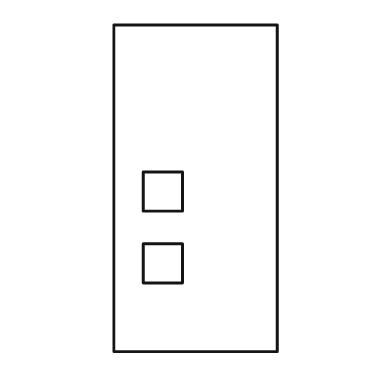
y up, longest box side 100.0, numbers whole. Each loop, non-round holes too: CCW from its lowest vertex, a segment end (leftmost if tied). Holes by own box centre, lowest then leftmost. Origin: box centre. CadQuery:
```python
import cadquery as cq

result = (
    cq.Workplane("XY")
    .moveTo(-25.0, -50.0)
    .lineTo(25.0, -50.0)
    .lineTo(25.0, 50.0)
    .lineTo(-25.0, 50.0)
    .close()
    .moveTo(-16.0, -29.0)
    .lineTo(-4.0, -29.0)
    .lineTo(-4.0, -17.0)
    .lineTo(-16.0, -17.0)
    .close()
    .moveTo(-16.0, -7.0)
    .lineTo(-4.0, -7.0)
    .lineTo(-4.0, 5.0)
    .lineTo(-16.0, 5.0)
    .close()
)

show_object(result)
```